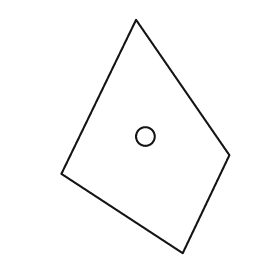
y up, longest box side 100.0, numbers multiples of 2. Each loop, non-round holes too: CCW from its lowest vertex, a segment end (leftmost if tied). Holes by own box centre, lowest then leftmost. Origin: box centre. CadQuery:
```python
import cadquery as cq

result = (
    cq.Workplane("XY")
    .moveTo(16.0, -50.0)
    .lineTo(36.0, -8.0)
    .lineTo(-4.0, 50.0)
    .lineTo(-36.0, -16.0)
    .close()
    .moveTo(0.0, 0.0)
    .circle(4.0)
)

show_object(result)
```